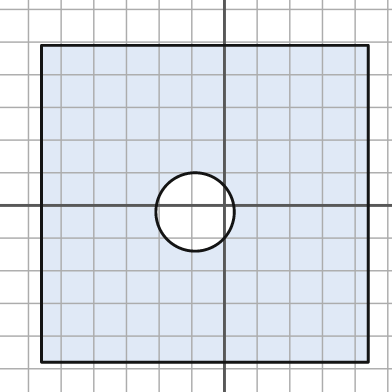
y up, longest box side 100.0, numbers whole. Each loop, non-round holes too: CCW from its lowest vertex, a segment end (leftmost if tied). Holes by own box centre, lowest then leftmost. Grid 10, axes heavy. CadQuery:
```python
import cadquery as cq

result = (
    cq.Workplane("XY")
    .moveTo(-56.0, -48.0)
    .lineTo(44.0, -48.0)
    .lineTo(44.0, 49.0)
    .lineTo(-56.0, 49.0)
    .close()
    .moveTo(-9.0, -2.0)
    .circle(12.0)
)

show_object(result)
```